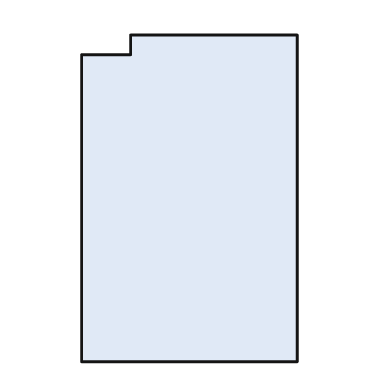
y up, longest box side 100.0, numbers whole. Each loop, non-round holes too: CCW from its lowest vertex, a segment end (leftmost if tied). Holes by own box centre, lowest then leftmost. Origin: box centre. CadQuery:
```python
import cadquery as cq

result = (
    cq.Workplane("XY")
    .moveTo(-33.0, -50.0)
    .lineTo(33.0, -50.0)
    .lineTo(33.0, 50.0)
    .lineTo(-18.0, 50.0)
    .lineTo(-18.0, 44.0)
    .lineTo(-33.0, 44.0)
    .close()
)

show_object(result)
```